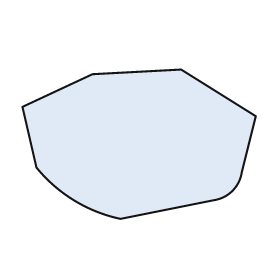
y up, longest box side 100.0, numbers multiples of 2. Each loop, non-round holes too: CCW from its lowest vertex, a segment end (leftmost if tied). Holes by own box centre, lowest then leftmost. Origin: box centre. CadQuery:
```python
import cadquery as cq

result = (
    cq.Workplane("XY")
    .moveTo(-8.0, -32.0)
    .lineTo(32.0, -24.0)
    .threePointArc((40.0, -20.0), (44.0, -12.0))
    .lineTo(50.0, 12.0)
    .lineTo(18.0, 32.0)
    .lineTo(-20.0, 30.0)
    .lineTo(-50.0, 16.0)
    .lineTo(-44.0, -10.0)
    .threePointArc((-28.0, -24.0), (-8.0, -32.0))
    .close()
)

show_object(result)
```